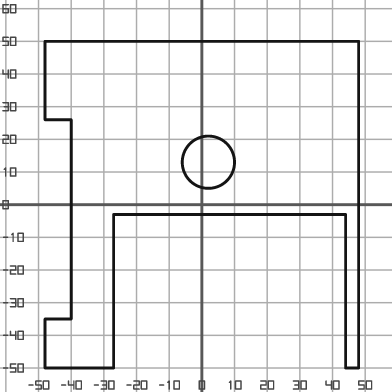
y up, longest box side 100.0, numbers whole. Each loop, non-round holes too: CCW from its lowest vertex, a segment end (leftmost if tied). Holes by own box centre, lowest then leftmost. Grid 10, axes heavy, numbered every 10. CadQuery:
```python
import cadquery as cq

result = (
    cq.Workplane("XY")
    .moveTo(-48.0, -50.0)
    .lineTo(-27.0, -50.0)
    .lineTo(-27.0, -3.0)
    .lineTo(44.0, -3.0)
    .lineTo(44.0, -50.0)
    .lineTo(48.0, -50.0)
    .lineTo(48.0, 50.0)
    .lineTo(-48.0, 50.0)
    .lineTo(-48.0, 26.0)
    .lineTo(-40.0, 26.0)
    .lineTo(-40.0, -35.0)
    .lineTo(-48.0, -35.0)
    .close()
    .moveTo(2.0, 13.0)
    .circle(8.0)
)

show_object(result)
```